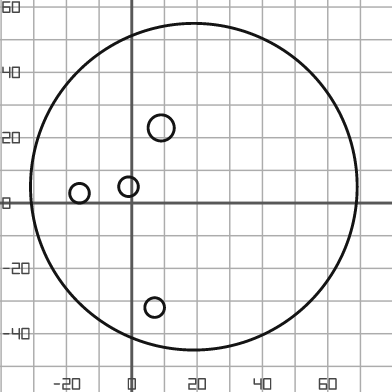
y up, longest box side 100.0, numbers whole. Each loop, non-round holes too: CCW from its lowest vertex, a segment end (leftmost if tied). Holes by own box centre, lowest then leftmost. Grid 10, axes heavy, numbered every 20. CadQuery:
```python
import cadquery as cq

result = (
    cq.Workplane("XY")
    .moveTo(19.0, 5.0)
    .circle(50.0)
    .moveTo(7.0, -32.0)
    .circle(3.0)
    .moveTo(-16.0, 3.0)
    .circle(3.0)
    .moveTo(-1.0, 5.0)
    .circle(3.0)
    .moveTo(9.0, 23.0)
    .circle(4.0)
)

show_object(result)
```